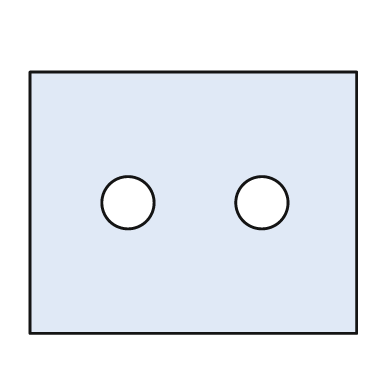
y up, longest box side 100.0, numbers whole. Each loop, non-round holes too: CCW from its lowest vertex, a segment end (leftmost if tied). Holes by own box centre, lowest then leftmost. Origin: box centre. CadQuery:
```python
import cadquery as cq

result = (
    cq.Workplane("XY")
    .moveTo(-50.0, -40.0)
    .lineTo(50.0, -40.0)
    .lineTo(50.0, 40.0)
    .lineTo(-50.0, 40.0)
    .close()
    .moveTo(-20.0, 0.0)
    .circle(8.0)
    .moveTo(21.0, 0.0)
    .circle(8.0)
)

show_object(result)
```